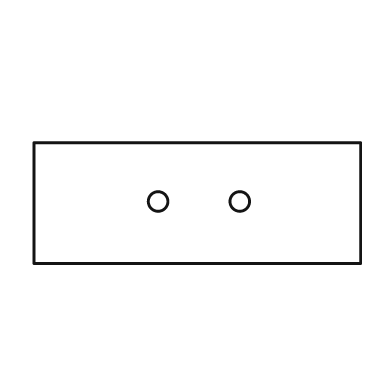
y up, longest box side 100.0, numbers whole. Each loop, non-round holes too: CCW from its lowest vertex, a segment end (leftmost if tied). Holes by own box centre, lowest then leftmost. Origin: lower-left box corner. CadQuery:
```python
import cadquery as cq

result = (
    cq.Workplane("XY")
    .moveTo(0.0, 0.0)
    .lineTo(100.0, 0.0)
    .lineTo(100.0, 37.0)
    .lineTo(0.0, 37.0)
    .close()
    .moveTo(38.0, 19.0)
    .circle(3.0)
    .moveTo(63.0, 19.0)
    .circle(3.0)
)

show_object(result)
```